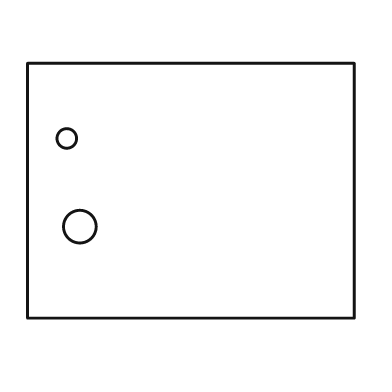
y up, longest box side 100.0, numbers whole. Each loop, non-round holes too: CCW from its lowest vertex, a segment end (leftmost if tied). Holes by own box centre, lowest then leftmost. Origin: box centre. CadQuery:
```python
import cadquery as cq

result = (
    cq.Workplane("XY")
    .moveTo(-50.0, -39.0)
    .lineTo(50.0, -39.0)
    .lineTo(50.0, 39.0)
    .lineTo(-50.0, 39.0)
    .close()
    .moveTo(-34.0, -11.0)
    .circle(5.0)
    .moveTo(-38.0, 16.0)
    .circle(3.0)
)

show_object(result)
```